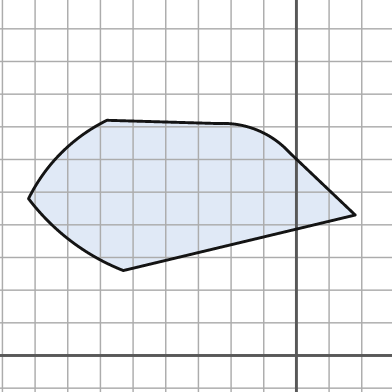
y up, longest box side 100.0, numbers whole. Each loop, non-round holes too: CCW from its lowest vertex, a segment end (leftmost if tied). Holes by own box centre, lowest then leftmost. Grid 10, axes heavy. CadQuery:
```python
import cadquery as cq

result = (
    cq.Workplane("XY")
    .moveTo(-53.0, 26.0)
    .lineTo(18.0, 43.0)
    .lineTo(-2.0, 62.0)
    .threePointArc((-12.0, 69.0), (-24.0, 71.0))
    .lineTo(-58.0, 72.0)
    .threePointArc((-72.0, 62.0), (-82.0, 48.0))
    .threePointArc((-69.0, 35.0), (-53.0, 26.0))
    .close()
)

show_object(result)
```